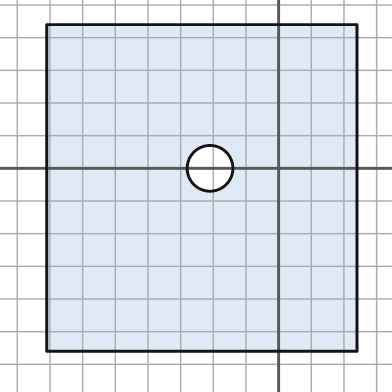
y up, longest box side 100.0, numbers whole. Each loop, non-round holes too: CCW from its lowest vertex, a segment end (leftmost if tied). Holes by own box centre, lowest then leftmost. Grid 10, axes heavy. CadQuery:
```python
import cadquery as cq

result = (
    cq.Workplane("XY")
    .moveTo(-71.0, -56.0)
    .lineTo(24.0, -56.0)
    .lineTo(24.0, 44.0)
    .lineTo(-71.0, 44.0)
    .close()
    .moveTo(-21.0, 0.0)
    .circle(7.0)
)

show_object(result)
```